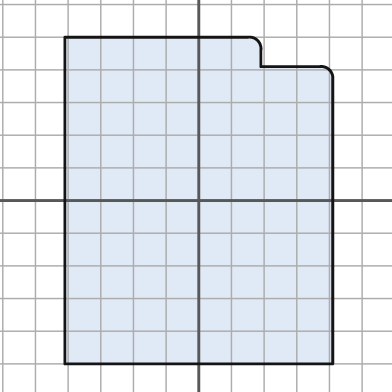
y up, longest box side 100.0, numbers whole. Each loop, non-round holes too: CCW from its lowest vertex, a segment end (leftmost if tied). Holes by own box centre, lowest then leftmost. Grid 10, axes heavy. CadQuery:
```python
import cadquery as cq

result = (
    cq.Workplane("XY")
    .moveTo(-41.0, -50.0)
    .lineTo(41.0, -50.0)
    .lineTo(41.0, 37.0)
    .threePointArc((40.0, 40.0), (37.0, 41.0))
    .lineTo(19.0, 41.0)
    .lineTo(19.0, 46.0)
    .threePointArc((18.0, 49.0), (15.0, 50.0))
    .lineTo(-41.0, 50.0)
    .close()
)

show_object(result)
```